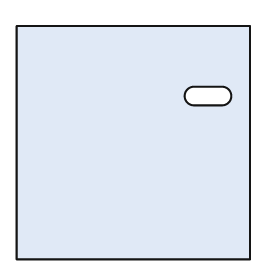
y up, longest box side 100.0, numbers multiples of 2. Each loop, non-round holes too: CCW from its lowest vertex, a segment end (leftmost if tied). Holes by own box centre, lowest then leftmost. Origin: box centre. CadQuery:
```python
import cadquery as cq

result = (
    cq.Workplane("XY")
    .moveTo(-50.0, -50.0)
    .lineTo(50.0, -50.0)
    .lineTo(50.0, 50.0)
    .lineTo(-50.0, 50.0)
    .close()
    .moveTo(26.0, 16.0)
    .lineTo(38.0, 16.0)
    .threePointArc((42.0, 20.0), (38.0, 24.0))
    .lineTo(26.0, 24.0)
    .threePointArc((22.0, 20.0), (26.0, 16.0))
    .close()
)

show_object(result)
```